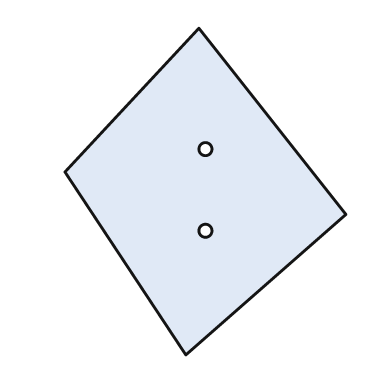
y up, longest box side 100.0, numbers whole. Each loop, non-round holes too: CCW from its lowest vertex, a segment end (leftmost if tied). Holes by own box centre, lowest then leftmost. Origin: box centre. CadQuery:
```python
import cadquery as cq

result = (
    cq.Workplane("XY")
    .moveTo(-6.0, -50.0)
    .lineTo(43.0, -7.0)
    .lineTo(-2.0, 50.0)
    .lineTo(-43.0, 6.0)
    .close()
    .moveTo(0.0, -12.0)
    .circle(2.0)
    .moveTo(0.0, 13.0)
    .circle(2.0)
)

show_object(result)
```